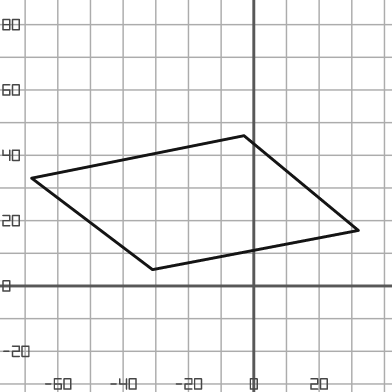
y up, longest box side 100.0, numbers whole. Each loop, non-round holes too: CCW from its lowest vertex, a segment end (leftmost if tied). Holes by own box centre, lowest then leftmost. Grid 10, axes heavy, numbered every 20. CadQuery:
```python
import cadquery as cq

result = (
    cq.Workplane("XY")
    .moveTo(-31.0, 5.0)
    .lineTo(32.0, 17.0)
    .lineTo(-3.0, 46.0)
    .lineTo(-68.0, 33.0)
    .close()
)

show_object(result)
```